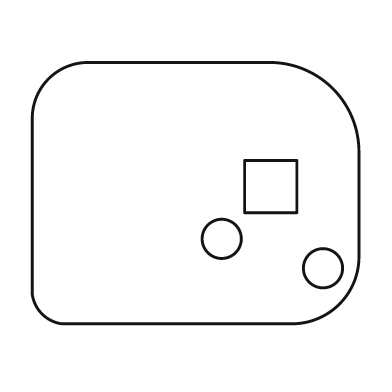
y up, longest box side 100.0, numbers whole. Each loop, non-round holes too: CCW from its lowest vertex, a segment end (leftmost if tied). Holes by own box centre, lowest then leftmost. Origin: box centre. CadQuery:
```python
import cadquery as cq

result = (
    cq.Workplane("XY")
    .moveTo(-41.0, -40.0)
    .lineTo(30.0, -40.0)
    .threePointArc((44.0, -34.0), (50.0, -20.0))
    .lineTo(50.0, 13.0)
    .threePointArc((42.0, 32.0), (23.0, 40.0))
    .lineTo(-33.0, 40.0)
    .threePointArc((-45.0, 35.0), (-50.0, 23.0))
    .lineTo(-50.0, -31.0)
    .threePointArc((-47.0, -37.0), (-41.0, -40.0))
    .close()
    .moveTo(39.0, -23.0)
    .circle(6.0)
    .moveTo(8.0, -14.0)
    .circle(6.0)
    .moveTo(15.0, -6.0)
    .lineTo(31.0, -6.0)
    .lineTo(31.0, 10.0)
    .lineTo(15.0, 10.0)
    .close()
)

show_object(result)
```